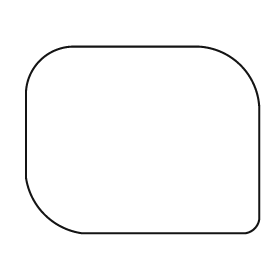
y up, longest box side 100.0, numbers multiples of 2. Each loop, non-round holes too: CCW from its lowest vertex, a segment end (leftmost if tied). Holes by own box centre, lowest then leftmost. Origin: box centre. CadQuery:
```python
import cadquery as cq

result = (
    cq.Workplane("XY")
    .moveTo(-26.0, -40.0)
    .lineTo(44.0, -40.0)
    .threePointArc((48.0, -38.0), (50.0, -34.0))
    .lineTo(50.0, 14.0)
    .threePointArc((42.0, 32.0), (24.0, 40.0))
    .lineTo(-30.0, 40.0)
    .threePointArc((-44.0, 34.0), (-50.0, 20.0))
    .lineTo(-50.0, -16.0)
    .threePointArc((-42.0, -32.0), (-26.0, -40.0))
    .close()
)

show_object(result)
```